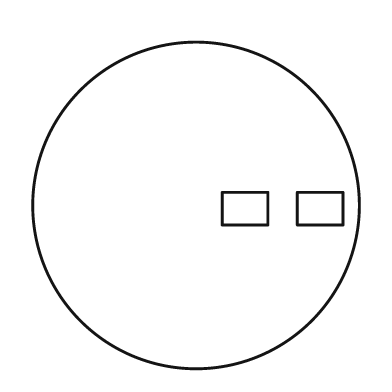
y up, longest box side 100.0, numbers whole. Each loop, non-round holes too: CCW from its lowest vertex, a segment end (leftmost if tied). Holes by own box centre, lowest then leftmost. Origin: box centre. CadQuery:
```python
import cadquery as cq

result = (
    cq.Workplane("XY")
    .moveTo(0.0, 0.0)
    .circle(50.0)
    .moveTo(8.0, -6.0)
    .lineTo(22.0, -6.0)
    .lineTo(22.0, 4.0)
    .lineTo(8.0, 4.0)
    .close()
    .moveTo(31.0, -6.0)
    .lineTo(45.0, -6.0)
    .lineTo(45.0, 4.0)
    .lineTo(31.0, 4.0)
    .close()
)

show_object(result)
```